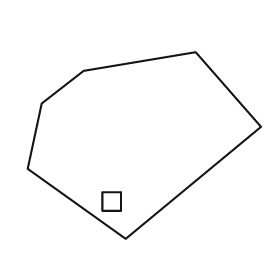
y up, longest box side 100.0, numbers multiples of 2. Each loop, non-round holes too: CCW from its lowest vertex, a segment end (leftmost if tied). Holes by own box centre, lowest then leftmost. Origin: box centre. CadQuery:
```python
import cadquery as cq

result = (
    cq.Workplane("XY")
    .moveTo(-8.0, -40.0)
    .lineTo(50.0, 8.0)
    .lineTo(22.0, 40.0)
    .lineTo(-26.0, 32.0)
    .lineTo(-44.0, 18.0)
    .lineTo(-50.0, -10.0)
    .close()
    .moveTo(-18.0, -28.0)
    .lineTo(-10.0, -28.0)
    .lineTo(-10.0, -20.0)
    .lineTo(-18.0, -20.0)
    .close()
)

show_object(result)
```